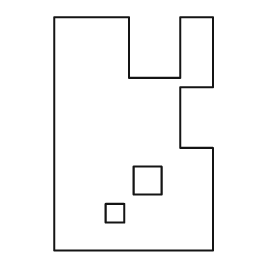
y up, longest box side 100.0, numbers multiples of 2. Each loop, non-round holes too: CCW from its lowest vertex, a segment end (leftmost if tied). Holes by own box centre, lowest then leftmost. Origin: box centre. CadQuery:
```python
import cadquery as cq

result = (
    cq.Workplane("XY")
    .moveTo(-34.0, -50.0)
    .lineTo(34.0, -50.0)
    .lineTo(34.0, -6.0)
    .lineTo(20.0, -6.0)
    .lineTo(20.0, 20.0)
    .lineTo(34.0, 20.0)
    .lineTo(34.0, 50.0)
    .lineTo(20.0, 50.0)
    .lineTo(20.0, 24.0)
    .lineTo(-2.0, 24.0)
    .lineTo(-2.0, 50.0)
    .lineTo(-34.0, 50.0)
    .close()
    .moveTo(-12.0, -38.0)
    .lineTo(-4.0, -38.0)
    .lineTo(-4.0, -30.0)
    .lineTo(-12.0, -30.0)
    .close()
    .moveTo(0.0, -26.0)
    .lineTo(12.0, -26.0)
    .lineTo(12.0, -14.0)
    .lineTo(0.0, -14.0)
    .close()
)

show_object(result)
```